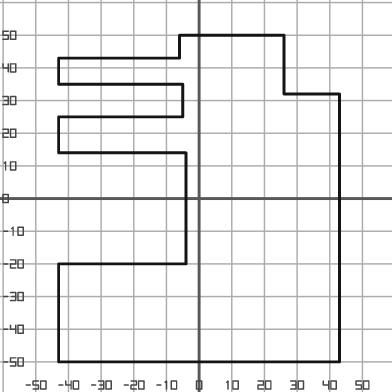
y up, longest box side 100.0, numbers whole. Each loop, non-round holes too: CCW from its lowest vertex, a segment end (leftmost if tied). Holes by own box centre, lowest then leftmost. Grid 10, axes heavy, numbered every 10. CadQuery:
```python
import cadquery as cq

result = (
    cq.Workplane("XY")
    .moveTo(-43.0, -50.0)
    .lineTo(43.0, -50.0)
    .lineTo(43.0, 32.0)
    .lineTo(26.0, 32.0)
    .lineTo(26.0, 50.0)
    .lineTo(-6.0, 50.0)
    .lineTo(-6.0, 43.0)
    .lineTo(-43.0, 43.0)
    .lineTo(-43.0, 35.0)
    .lineTo(-5.0, 35.0)
    .lineTo(-5.0, 25.0)
    .lineTo(-43.0, 25.0)
    .lineTo(-43.0, 14.0)
    .lineTo(-4.0, 14.0)
    .lineTo(-4.0, -20.0)
    .lineTo(-43.0, -20.0)
    .close()
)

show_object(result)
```